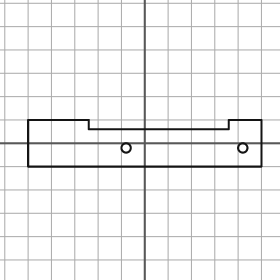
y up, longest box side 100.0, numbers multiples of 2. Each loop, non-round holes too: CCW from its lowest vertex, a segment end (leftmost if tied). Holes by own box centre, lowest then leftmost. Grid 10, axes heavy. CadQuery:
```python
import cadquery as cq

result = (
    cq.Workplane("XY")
    .moveTo(-50.0, -10.0)
    .lineTo(50.0, -10.0)
    .lineTo(50.0, 10.0)
    .lineTo(36.0, 10.0)
    .lineTo(36.0, 6.0)
    .lineTo(-24.0, 6.0)
    .lineTo(-24.0, 10.0)
    .lineTo(-50.0, 10.0)
    .close()
    .moveTo(-8.0, -2.0)
    .circle(2.0)
    .moveTo(42.0, -2.0)
    .circle(2.0)
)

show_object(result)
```